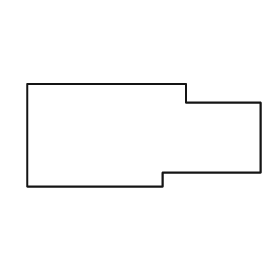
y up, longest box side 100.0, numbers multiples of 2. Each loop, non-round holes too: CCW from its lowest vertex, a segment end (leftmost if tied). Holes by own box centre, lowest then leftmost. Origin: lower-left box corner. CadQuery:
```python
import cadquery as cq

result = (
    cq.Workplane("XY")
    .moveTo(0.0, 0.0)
    .lineTo(58.0, 0.0)
    .lineTo(58.0, 6.0)
    .lineTo(100.0, 6.0)
    .lineTo(100.0, 36.0)
    .lineTo(68.0, 36.0)
    .lineTo(68.0, 44.0)
    .lineTo(0.0, 44.0)
    .close()
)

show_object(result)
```